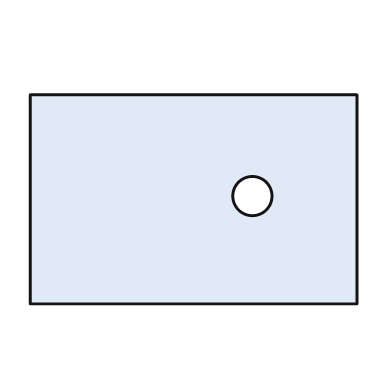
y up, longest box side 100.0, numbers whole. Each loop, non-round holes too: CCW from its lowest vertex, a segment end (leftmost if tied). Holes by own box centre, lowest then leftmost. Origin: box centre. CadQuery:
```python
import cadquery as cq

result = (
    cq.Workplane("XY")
    .moveTo(-50.0, -32.0)
    .lineTo(50.0, -32.0)
    .lineTo(50.0, 32.0)
    .lineTo(-50.0, 32.0)
    .close()
    .moveTo(18.0, 1.0)
    .circle(6.0)
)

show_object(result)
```